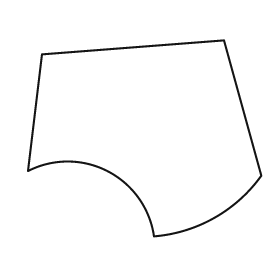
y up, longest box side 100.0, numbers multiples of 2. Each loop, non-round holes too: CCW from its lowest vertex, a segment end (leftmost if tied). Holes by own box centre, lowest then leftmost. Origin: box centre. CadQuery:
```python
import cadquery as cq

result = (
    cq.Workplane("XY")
    .moveTo(4.0, -42.0)
    .threePointArc((30.0, -34.0), (50.0, -16.0))
    .lineTo(34.0, 42.0)
    .lineTo(-44.0, 36.0)
    .lineTo(-50.0, -14.0)
    .threePointArc((-16.0, -14.0), (4.0, -42.0))
    .close()
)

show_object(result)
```